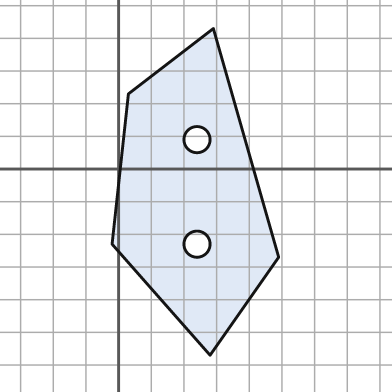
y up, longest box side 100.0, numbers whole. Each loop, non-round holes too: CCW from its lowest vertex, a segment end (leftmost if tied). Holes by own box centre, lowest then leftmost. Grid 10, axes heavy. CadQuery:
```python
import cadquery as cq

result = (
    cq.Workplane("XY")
    .moveTo(28.0, -57.0)
    .lineTo(49.0, -27.0)
    .lineTo(29.0, 43.0)
    .lineTo(3.0, 23.0)
    .lineTo(-2.0, -23.0)
    .close()
    .moveTo(24.0, -23.0)
    .circle(4.0)
    .moveTo(24.0, 9.0)
    .circle(4.0)
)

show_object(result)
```